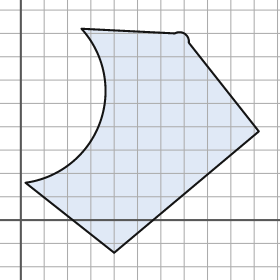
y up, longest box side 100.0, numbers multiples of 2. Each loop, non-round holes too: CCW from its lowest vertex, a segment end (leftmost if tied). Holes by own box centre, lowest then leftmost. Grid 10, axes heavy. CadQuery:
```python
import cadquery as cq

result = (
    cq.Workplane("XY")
    .moveTo(40.0, -14.0)
    .lineTo(102.0, 38.0)
    .lineTo(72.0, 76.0)
    .threePointArc((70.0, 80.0), (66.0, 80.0))
    .lineTo(26.0, 82.0)
    .threePointArc((34.0, 42.0), (2.0, 16.0))
    .close()
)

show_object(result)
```